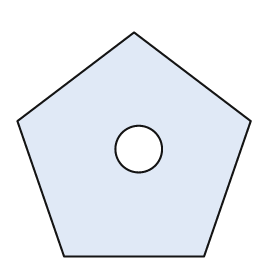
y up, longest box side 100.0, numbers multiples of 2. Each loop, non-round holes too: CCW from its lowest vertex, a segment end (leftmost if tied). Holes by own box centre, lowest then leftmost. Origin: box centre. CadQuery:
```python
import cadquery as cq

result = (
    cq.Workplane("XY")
    .moveTo(-30.0, -48.0)
    .lineTo(30.0, -48.0)
    .lineTo(50.0, 10.0)
    .lineTo(0.0, 48.0)
    .lineTo(-50.0, 10.0)
    .close()
    .moveTo(2.0, -2.0)
    .circle(10.0)
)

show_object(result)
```